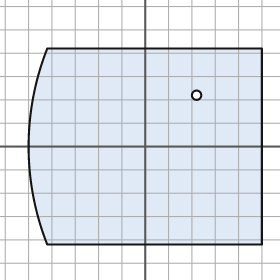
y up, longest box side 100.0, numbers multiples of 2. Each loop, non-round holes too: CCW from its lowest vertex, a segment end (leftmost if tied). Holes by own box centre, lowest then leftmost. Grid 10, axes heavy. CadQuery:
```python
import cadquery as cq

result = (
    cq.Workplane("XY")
    .moveTo(-42.0, -42.0)
    .lineTo(50.0, -42.0)
    .lineTo(50.0, 42.0)
    .lineTo(-42.0, 42.0)
    .threePointArc((-50.0, 0.0), (-42.0, -42.0))
    .close()
    .moveTo(22.0, 22.0)
    .circle(2.0)
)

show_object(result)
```